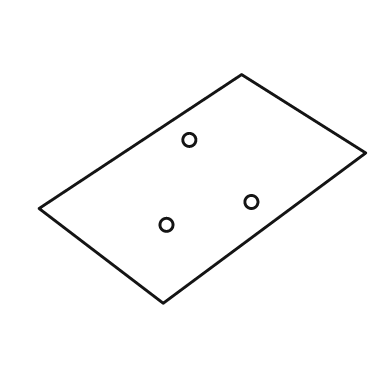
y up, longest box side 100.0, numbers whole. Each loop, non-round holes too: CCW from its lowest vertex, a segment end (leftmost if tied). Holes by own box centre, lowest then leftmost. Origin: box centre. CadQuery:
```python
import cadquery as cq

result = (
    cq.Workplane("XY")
    .moveTo(-12.0, -35.0)
    .lineTo(50.0, 11.0)
    .lineTo(12.0, 35.0)
    .lineTo(-50.0, -6.0)
    .close()
    .moveTo(-11.0, -11.0)
    .circle(2.0)
    .moveTo(15.0, -4.0)
    .circle(2.0)
    .moveTo(-4.0, 15.0)
    .circle(2.0)
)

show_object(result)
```